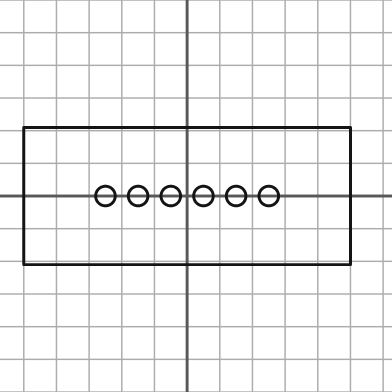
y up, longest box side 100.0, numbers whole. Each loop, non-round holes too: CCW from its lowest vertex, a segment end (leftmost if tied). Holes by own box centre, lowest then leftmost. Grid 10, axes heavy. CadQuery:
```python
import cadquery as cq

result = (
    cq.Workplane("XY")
    .moveTo(-50.0, -21.0)
    .lineTo(50.0, -21.0)
    .lineTo(50.0, 21.0)
    .lineTo(-50.0, 21.0)
    .close()
    .moveTo(-25.0, 0.0)
    .circle(3.0)
    .moveTo(-15.0, 0.0)
    .circle(3.0)
    .moveTo(-5.0, 0.0)
    .circle(3.0)
    .moveTo(5.0, 0.0)
    .circle(3.0)
    .moveTo(15.0, 0.0)
    .circle(3.0)
    .moveTo(25.0, 0.0)
    .circle(3.0)
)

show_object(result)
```